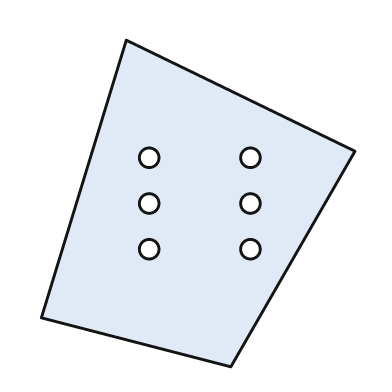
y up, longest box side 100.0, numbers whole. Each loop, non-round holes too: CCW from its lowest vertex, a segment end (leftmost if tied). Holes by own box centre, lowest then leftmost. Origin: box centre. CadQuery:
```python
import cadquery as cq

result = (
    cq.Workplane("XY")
    .moveTo(10.0, -50.0)
    .lineTo(48.0, 16.0)
    .lineTo(-22.0, 50.0)
    .lineTo(-48.0, -35.0)
    .close()
    .moveTo(-15.0, -14.0)
    .circle(3.0)
    .moveTo(16.0, -14.0)
    .circle(3.0)
    .moveTo(-15.0, 0.0)
    .circle(3.0)
    .moveTo(16.0, 0.0)
    .circle(3.0)
    .moveTo(-15.0, 14.0)
    .circle(3.0)
    .moveTo(16.0, 14.0)
    .circle(3.0)
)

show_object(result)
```